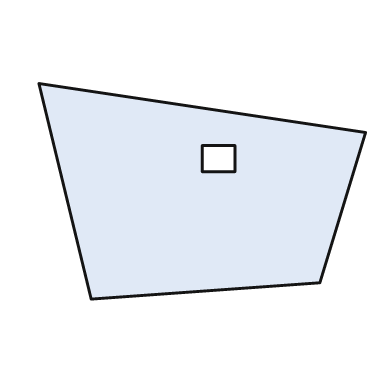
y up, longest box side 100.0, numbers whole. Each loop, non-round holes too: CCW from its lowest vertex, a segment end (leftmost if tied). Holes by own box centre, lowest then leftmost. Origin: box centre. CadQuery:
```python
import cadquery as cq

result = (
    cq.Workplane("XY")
    .moveTo(-34.0, -33.0)
    .lineTo(36.0, -28.0)
    .lineTo(50.0, 18.0)
    .lineTo(-50.0, 33.0)
    .close()
    .moveTo(0.0, 6.0)
    .lineTo(10.0, 6.0)
    .lineTo(10.0, 14.0)
    .lineTo(0.0, 14.0)
    .close()
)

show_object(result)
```